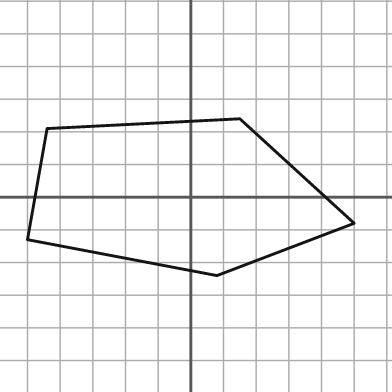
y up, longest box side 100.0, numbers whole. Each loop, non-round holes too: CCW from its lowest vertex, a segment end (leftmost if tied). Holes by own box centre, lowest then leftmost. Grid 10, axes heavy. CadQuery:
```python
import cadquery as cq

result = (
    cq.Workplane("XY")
    .moveTo(8.0, -24.0)
    .lineTo(50.0, -8.0)
    .lineTo(15.0, 24.0)
    .lineTo(-44.0, 21.0)
    .lineTo(-50.0, -13.0)
    .close()
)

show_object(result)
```